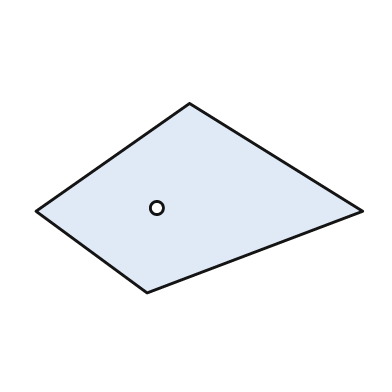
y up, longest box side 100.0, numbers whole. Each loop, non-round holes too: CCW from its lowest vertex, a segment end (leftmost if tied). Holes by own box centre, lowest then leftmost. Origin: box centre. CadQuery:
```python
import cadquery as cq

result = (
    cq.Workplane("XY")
    .moveTo(-16.0, -29.0)
    .lineTo(50.0, -4.0)
    .lineTo(-3.0, 29.0)
    .lineTo(-50.0, -4.0)
    .close()
    .moveTo(-13.0, -3.0)
    .circle(2.0)
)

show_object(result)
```